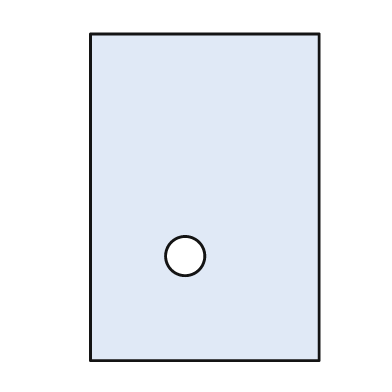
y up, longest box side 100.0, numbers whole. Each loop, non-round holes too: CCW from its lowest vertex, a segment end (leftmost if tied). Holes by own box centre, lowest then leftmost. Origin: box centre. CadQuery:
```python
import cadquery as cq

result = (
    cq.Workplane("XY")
    .moveTo(-35.0, -50.0)
    .lineTo(35.0, -50.0)
    .lineTo(35.0, 50.0)
    .lineTo(-35.0, 50.0)
    .close()
    .moveTo(-6.0, -18.0)
    .circle(6.0)
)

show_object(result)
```